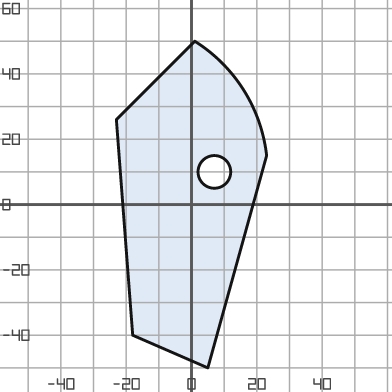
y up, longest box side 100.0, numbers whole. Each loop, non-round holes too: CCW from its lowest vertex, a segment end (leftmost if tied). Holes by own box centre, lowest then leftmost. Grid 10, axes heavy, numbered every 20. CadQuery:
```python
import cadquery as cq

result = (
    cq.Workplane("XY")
    .moveTo(5.0, -50.0)
    .lineTo(23.0, 15.0)
    .threePointArc((16.0, 35.0), (1.0, 50.0))
    .lineTo(-23.0, 26.0)
    .lineTo(-18.0, -40.0)
    .close()
    .moveTo(7.0, 10.0)
    .circle(5.0)
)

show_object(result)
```